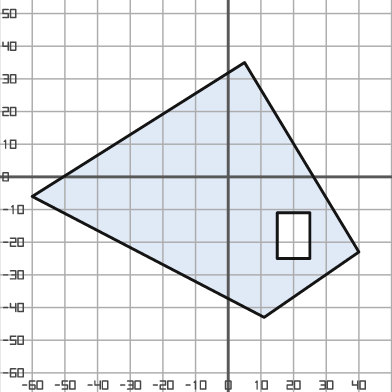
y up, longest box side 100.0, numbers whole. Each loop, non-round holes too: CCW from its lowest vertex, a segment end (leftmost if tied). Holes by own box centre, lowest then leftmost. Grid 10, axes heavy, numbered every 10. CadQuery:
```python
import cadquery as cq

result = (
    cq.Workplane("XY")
    .moveTo(11.0, -43.0)
    .lineTo(40.0, -23.0)
    .lineTo(5.0, 35.0)
    .lineTo(-60.0, -6.0)
    .close()
    .moveTo(15.0, -25.0)
    .lineTo(25.0, -25.0)
    .lineTo(25.0, -11.0)
    .lineTo(15.0, -11.0)
    .close()
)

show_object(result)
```